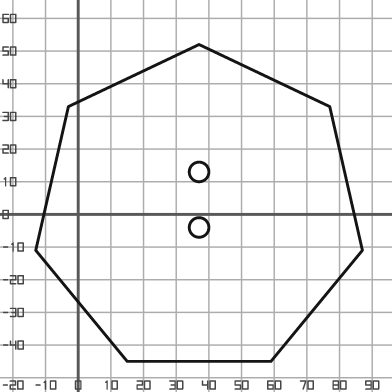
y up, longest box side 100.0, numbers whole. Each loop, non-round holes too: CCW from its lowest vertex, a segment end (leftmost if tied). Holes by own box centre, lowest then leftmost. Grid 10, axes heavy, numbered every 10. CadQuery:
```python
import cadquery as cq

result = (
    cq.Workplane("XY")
    .moveTo(15.0, -45.0)
    .lineTo(59.0, -45.0)
    .lineTo(87.0, -11.0)
    .lineTo(77.0, 33.0)
    .lineTo(37.0, 52.0)
    .lineTo(-3.0, 33.0)
    .lineTo(-13.0, -11.0)
    .close()
    .moveTo(37.0, -4.0)
    .circle(3.0)
    .moveTo(37.0, 13.0)
    .circle(3.0)
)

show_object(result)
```